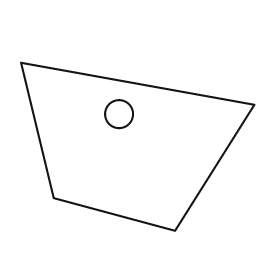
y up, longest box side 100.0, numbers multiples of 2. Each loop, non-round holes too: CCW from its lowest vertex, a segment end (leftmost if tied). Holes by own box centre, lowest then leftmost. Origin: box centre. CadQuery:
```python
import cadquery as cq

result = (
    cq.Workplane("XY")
    .moveTo(16.0, -36.0)
    .lineTo(50.0, 18.0)
    .lineTo(-50.0, 36.0)
    .lineTo(-36.0, -22.0)
    .close()
    .moveTo(-8.0, 14.0)
    .circle(6.0)
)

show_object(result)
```